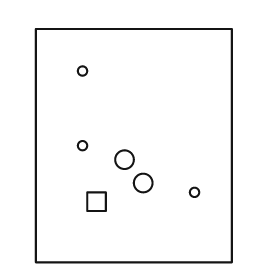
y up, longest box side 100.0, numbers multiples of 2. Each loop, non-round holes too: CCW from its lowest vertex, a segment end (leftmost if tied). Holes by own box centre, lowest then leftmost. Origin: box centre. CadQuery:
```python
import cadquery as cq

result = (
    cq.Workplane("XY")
    .moveTo(-42.0, -50.0)
    .lineTo(42.0, -50.0)
    .lineTo(42.0, 50.0)
    .lineTo(-42.0, 50.0)
    .close()
    .moveTo(-20.0, -28.0)
    .lineTo(-12.0, -28.0)
    .lineTo(-12.0, -20.0)
    .lineTo(-20.0, -20.0)
    .close()
    .moveTo(26.0, -20.0)
    .circle(2.0)
    .moveTo(4.0, -16.0)
    .circle(4.0)
    .moveTo(-4.0, -6.0)
    .circle(4.0)
    .moveTo(-22.0, 0.0)
    .circle(2.0)
    .moveTo(-22.0, 32.0)
    .circle(2.0)
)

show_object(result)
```